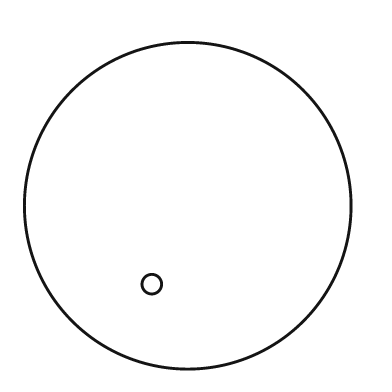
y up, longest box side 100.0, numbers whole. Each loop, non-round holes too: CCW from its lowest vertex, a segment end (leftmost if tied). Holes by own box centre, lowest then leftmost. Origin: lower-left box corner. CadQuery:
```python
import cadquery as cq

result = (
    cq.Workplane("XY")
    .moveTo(50.0, 50.0)
    .circle(50.0)
    .moveTo(39.0, 26.0)
    .circle(3.0)
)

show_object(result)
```